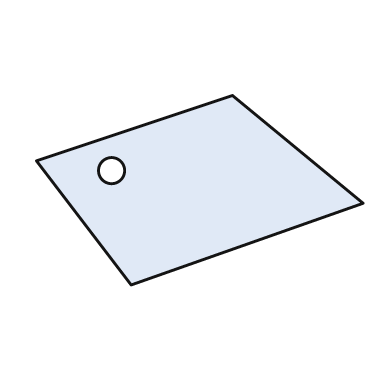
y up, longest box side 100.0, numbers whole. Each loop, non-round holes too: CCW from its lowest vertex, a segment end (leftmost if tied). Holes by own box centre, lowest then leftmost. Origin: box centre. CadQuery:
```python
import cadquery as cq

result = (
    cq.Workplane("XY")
    .moveTo(-21.0, -29.0)
    .lineTo(50.0, -4.0)
    .lineTo(10.0, 29.0)
    .lineTo(-50.0, 9.0)
    .close()
    .moveTo(-27.0, 6.0)
    .circle(4.0)
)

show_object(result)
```